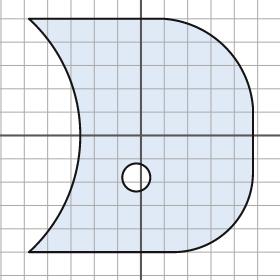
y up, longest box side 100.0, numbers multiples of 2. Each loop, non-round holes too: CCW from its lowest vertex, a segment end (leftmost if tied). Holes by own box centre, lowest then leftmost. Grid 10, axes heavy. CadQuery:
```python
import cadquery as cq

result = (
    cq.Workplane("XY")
    .moveTo(-48.0, -50.0)
    .lineTo(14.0, -50.0)
    .threePointArc((38.0, -40.0), (48.0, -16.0))
    .lineTo(48.0, 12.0)
    .threePointArc((36.0, 38.0), (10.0, 50.0))
    .lineTo(-48.0, 50.0)
    .threePointArc((-26.0, 0.0), (-48.0, -50.0))
    .close()
    .moveTo(-2.0, -18.0)
    .circle(6.0)
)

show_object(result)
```